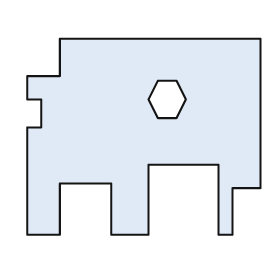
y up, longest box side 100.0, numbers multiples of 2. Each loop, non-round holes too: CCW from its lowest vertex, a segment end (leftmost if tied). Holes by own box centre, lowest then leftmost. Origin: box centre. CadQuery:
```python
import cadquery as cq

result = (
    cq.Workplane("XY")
    .moveTo(-50.0, -42.0)
    .lineTo(-36.0, -42.0)
    .lineTo(-36.0, -20.0)
    .lineTo(-14.0, -20.0)
    .lineTo(-14.0, -42.0)
    .lineTo(2.0, -42.0)
    .lineTo(2.0, -12.0)
    .lineTo(32.0, -12.0)
    .lineTo(32.0, -42.0)
    .lineTo(38.0, -42.0)
    .lineTo(38.0, -22.0)
    .lineTo(50.0, -22.0)
    .lineTo(50.0, 42.0)
    .lineTo(-36.0, 42.0)
    .lineTo(-36.0, 26.0)
    .lineTo(-50.0, 26.0)
    .lineTo(-50.0, 16.0)
    .lineTo(-44.0, 16.0)
    .lineTo(-44.0, 4.0)
    .lineTo(-50.0, 4.0)
    .close()
    .moveTo(6.0, 8.0)
    .lineTo(14.0, 8.0)
    .lineTo(18.0, 16.0)
    .lineTo(14.0, 24.0)
    .lineTo(6.0, 24.0)
    .lineTo(2.0, 16.0)
    .close()
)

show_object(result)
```